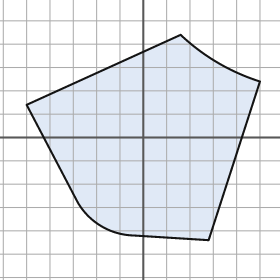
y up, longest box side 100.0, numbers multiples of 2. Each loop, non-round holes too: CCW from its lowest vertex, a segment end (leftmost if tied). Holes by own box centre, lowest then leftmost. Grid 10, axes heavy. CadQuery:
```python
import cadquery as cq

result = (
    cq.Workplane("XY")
    .moveTo(28.0, -44.0)
    .lineTo(50.0, 24.0)
    .threePointArc((32.0, 32.0), (16.0, 44.0))
    .lineTo(-50.0, 14.0)
    .lineTo(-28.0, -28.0)
    .threePointArc((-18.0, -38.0), (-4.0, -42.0))
    .close()
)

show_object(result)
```